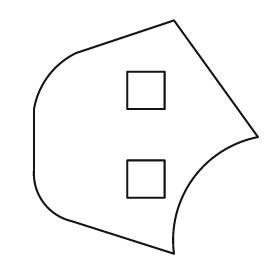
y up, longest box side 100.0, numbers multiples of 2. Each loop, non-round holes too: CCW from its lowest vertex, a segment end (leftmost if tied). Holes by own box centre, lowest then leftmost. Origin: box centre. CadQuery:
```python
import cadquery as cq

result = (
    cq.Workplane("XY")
    .moveTo(12.0, -50.0)
    .threePointArc((20.0, -18.0), (48.0, 0.0))
    .lineTo(12.0, 50.0)
    .lineTo(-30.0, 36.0)
    .threePointArc((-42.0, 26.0), (-48.0, 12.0))
    .lineTo(-48.0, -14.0)
    .threePointArc((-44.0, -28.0), (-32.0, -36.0))
    .close()
    .moveTo(-8.0, -26.0)
    .lineTo(8.0, -26.0)
    .lineTo(8.0, -10.0)
    .lineTo(-8.0, -10.0)
    .close()
    .moveTo(-8.0, 12.0)
    .lineTo(8.0, 12.0)
    .lineTo(8.0, 28.0)
    .lineTo(-8.0, 28.0)
    .close()
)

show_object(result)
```